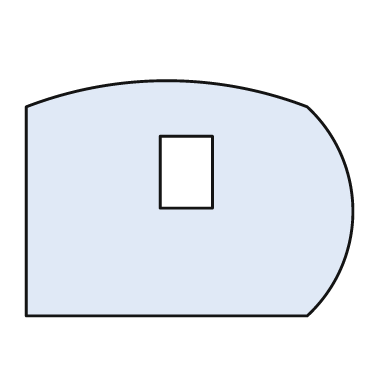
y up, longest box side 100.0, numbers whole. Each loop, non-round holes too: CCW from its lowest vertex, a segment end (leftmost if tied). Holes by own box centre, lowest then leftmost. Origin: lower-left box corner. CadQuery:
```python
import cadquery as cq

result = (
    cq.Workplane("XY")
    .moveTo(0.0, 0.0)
    .lineTo(86.0, 0.0)
    .threePointArc((100.0, 32.0), (86.0, 64.0))
    .threePointArc((43.0, 72.0), (0.0, 64.0))
    .close()
    .moveTo(41.0, 33.0)
    .lineTo(57.0, 33.0)
    .lineTo(57.0, 55.0)
    .lineTo(41.0, 55.0)
    .close()
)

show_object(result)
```